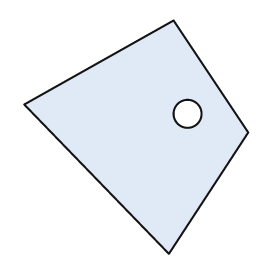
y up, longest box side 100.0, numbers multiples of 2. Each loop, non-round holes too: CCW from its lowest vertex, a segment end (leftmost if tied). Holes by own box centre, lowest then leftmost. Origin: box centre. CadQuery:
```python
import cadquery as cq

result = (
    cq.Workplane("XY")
    .moveTo(14.0, -50.0)
    .lineTo(48.0, 2.0)
    .lineTo(16.0, 50.0)
    .lineTo(-48.0, 14.0)
    .close()
    .moveTo(22.0, 10.0)
    .circle(6.0)
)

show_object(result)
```